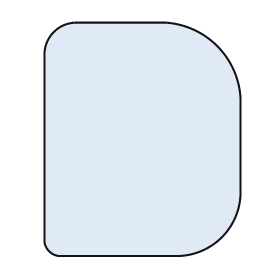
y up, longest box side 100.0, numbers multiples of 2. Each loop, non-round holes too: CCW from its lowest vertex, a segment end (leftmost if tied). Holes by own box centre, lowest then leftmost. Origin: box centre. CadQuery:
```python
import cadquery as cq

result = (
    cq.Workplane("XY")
    .moveTo(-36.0, -50.0)
    .lineTo(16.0, -50.0)
    .threePointArc((34.0, -42.0), (42.0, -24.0))
    .lineTo(42.0, 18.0)
    .threePointArc((32.0, 40.0), (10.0, 50.0))
    .lineTo(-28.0, 50.0)
    .threePointArc((-38.0, 46.0), (-42.0, 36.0))
    .lineTo(-42.0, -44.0)
    .threePointArc((-40.0, -48.0), (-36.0, -50.0))
    .close()
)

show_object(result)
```